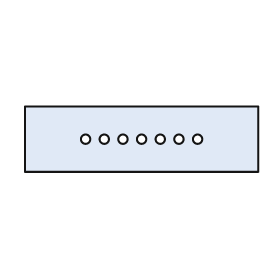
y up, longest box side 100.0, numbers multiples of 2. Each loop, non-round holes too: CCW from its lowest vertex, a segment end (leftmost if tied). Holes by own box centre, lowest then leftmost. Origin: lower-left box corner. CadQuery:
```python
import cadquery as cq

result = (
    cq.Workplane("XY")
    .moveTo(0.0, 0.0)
    .lineTo(100.0, 0.0)
    .lineTo(100.0, 28.0)
    .lineTo(0.0, 28.0)
    .close()
    .moveTo(26.0, 14.0)
    .circle(2.0)
    .moveTo(34.0, 14.0)
    .circle(2.0)
    .moveTo(42.0, 14.0)
    .circle(2.0)
    .moveTo(50.0, 14.0)
    .circle(2.0)
    .moveTo(58.0, 14.0)
    .circle(2.0)
    .moveTo(66.0, 14.0)
    .circle(2.0)
    .moveTo(74.0, 14.0)
    .circle(2.0)
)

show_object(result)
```